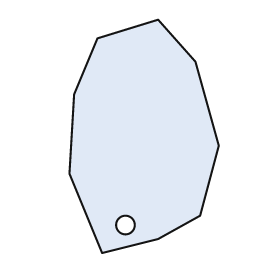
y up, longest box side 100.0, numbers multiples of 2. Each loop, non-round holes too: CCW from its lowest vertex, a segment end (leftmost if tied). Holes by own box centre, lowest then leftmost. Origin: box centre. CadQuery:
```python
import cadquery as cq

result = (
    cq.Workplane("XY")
    .moveTo(-18.0, -50.0)
    .lineTo(6.0, -44.0)
    .lineTo(24.0, -34.0)
    .lineTo(32.0, -4.0)
    .lineTo(22.0, 32.0)
    .lineTo(6.0, 50.0)
    .lineTo(-20.0, 42.0)
    .lineTo(-30.0, 18.0)
    .lineTo(-32.0, -16.0)
    .close()
    .moveTo(-8.0, -38.0)
    .circle(4.0)
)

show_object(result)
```